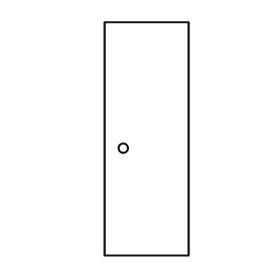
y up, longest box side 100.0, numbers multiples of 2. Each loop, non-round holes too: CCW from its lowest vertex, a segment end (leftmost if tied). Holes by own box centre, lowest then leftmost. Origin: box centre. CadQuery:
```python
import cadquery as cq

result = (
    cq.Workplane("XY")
    .moveTo(-18.0, -50.0)
    .lineTo(18.0, -50.0)
    .lineTo(18.0, 50.0)
    .lineTo(-18.0, 50.0)
    .close()
    .moveTo(-10.0, -4.0)
    .circle(2.0)
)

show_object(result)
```